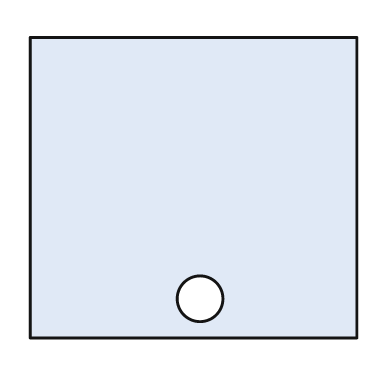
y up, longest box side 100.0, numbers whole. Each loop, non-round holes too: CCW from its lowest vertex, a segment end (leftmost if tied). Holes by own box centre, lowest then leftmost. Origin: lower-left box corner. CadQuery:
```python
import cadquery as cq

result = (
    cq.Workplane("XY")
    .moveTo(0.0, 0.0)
    .lineTo(100.0, 0.0)
    .lineTo(100.0, 92.0)
    .lineTo(0.0, 92.0)
    .close()
    .moveTo(52.0, 12.0)
    .circle(7.0)
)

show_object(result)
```